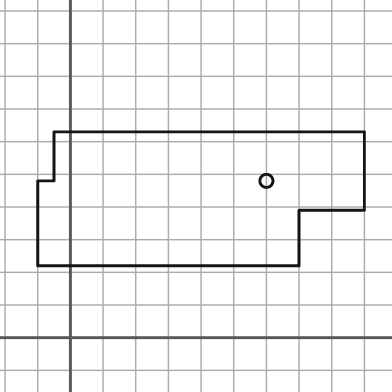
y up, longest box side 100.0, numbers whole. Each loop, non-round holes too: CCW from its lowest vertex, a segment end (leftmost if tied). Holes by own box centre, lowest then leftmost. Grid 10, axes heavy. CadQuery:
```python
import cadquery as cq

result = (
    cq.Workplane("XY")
    .moveTo(-10.0, 22.0)
    .lineTo(70.0, 22.0)
    .lineTo(70.0, 39.0)
    .lineTo(90.0, 39.0)
    .lineTo(90.0, 63.0)
    .lineTo(-5.0, 63.0)
    .lineTo(-5.0, 48.0)
    .lineTo(-10.0, 48.0)
    .close()
    .moveTo(60.0, 48.0)
    .circle(2.0)
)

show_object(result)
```